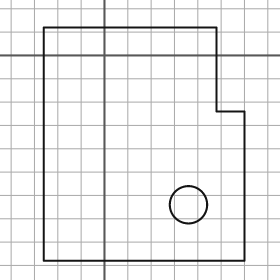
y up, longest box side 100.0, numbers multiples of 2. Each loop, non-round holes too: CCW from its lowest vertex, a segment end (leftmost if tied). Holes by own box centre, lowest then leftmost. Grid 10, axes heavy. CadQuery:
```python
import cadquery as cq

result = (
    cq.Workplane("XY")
    .moveTo(-26.0, -88.0)
    .lineTo(60.0, -88.0)
    .lineTo(60.0, -24.0)
    .lineTo(48.0, -24.0)
    .lineTo(48.0, 12.0)
    .lineTo(-26.0, 12.0)
    .close()
    .moveTo(36.0, -64.0)
    .circle(8.0)
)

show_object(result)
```